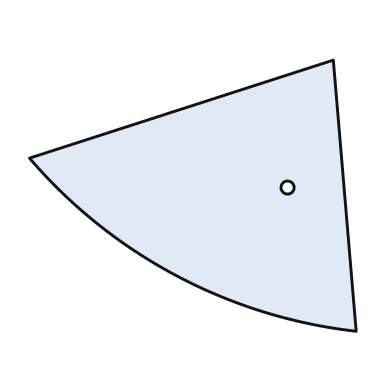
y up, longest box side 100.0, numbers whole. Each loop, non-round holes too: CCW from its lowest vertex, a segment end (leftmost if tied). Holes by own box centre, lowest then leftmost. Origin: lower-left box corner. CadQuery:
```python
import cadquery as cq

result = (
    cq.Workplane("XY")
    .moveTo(100.0, 0.0)
    .lineTo(93.0, 83.0)
    .lineTo(0.0, 53.0)
    .threePointArc((45.0, 17.0), (100.0, 0.0))
    .close()
    .moveTo(79.0, 44.0)
    .circle(2.0)
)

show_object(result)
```